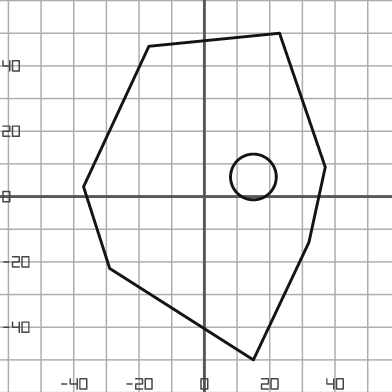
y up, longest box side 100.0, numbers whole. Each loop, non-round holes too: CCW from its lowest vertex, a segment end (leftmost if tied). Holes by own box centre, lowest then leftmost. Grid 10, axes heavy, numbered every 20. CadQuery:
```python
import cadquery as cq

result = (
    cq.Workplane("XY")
    .moveTo(15.0, -50.0)
    .lineTo(32.0, -14.0)
    .lineTo(37.0, 9.0)
    .lineTo(23.0, 50.0)
    .lineTo(-17.0, 46.0)
    .lineTo(-37.0, 3.0)
    .lineTo(-29.0, -22.0)
    .close()
    .moveTo(15.0, 6.0)
    .circle(7.0)
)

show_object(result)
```